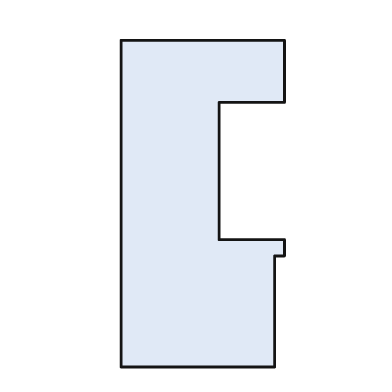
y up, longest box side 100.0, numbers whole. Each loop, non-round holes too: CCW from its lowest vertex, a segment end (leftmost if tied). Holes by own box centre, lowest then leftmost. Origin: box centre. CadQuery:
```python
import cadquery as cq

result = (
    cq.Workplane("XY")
    .moveTo(-25.0, -50.0)
    .lineTo(22.0, -50.0)
    .lineTo(22.0, -16.0)
    .lineTo(25.0, -16.0)
    .lineTo(25.0, -11.0)
    .lineTo(5.0, -11.0)
    .lineTo(5.0, 31.0)
    .lineTo(25.0, 31.0)
    .lineTo(25.0, 50.0)
    .lineTo(-25.0, 50.0)
    .close()
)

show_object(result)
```